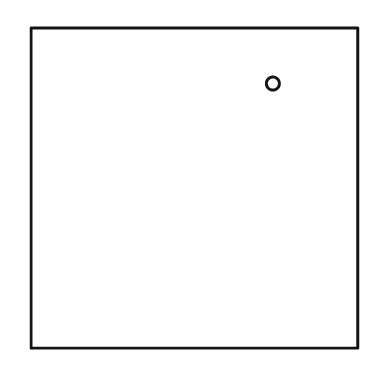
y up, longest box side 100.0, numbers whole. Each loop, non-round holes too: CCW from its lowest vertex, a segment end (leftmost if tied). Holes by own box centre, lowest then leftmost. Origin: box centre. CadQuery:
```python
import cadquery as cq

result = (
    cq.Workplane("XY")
    .moveTo(-50.0, -49.0)
    .lineTo(50.0, -49.0)
    .lineTo(50.0, 49.0)
    .lineTo(-50.0, 49.0)
    .close()
    .moveTo(24.0, 32.0)
    .circle(2.0)
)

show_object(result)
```